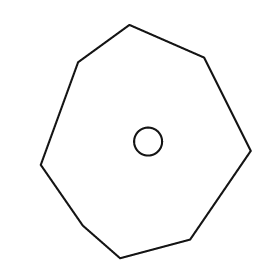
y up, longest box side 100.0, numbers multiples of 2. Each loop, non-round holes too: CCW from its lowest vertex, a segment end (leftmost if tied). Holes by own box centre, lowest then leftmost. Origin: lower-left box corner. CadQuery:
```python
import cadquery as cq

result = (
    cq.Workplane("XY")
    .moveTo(34.0, 0.0)
    .lineTo(64.0, 8.0)
    .lineTo(90.0, 46.0)
    .lineTo(70.0, 86.0)
    .lineTo(38.0, 100.0)
    .lineTo(16.0, 84.0)
    .lineTo(0.0, 40.0)
    .lineTo(18.0, 14.0)
    .close()
    .moveTo(46.0, 50.0)
    .circle(6.0)
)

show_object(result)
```